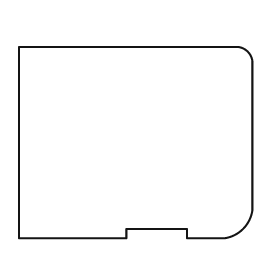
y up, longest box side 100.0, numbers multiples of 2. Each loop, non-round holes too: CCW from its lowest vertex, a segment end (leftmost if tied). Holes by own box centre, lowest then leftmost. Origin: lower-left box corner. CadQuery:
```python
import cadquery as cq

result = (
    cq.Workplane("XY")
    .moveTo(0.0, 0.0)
    .lineTo(46.0, 0.0)
    .lineTo(46.0, 4.0)
    .lineTo(72.0, 4.0)
    .lineTo(72.0, 0.0)
    .lineTo(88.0, 0.0)
    .threePointArc((96.0, 4.0), (100.0, 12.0))
    .lineTo(100.0, 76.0)
    .threePointArc((98.0, 80.0), (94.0, 82.0))
    .lineTo(0.0, 82.0)
    .close()
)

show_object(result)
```